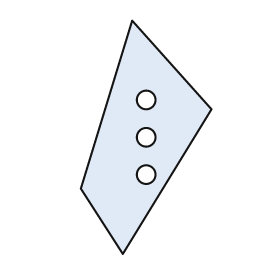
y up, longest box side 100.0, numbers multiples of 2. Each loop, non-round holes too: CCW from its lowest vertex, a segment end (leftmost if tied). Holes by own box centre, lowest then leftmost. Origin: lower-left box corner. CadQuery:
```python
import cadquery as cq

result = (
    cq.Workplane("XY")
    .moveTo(18.0, 0.0)
    .lineTo(56.0, 62.0)
    .lineTo(22.0, 100.0)
    .lineTo(0.0, 28.0)
    .close()
    .moveTo(28.0, 34.0)
    .circle(4.0)
    .moveTo(28.0, 50.0)
    .circle(4.0)
    .moveTo(28.0, 66.0)
    .circle(4.0)
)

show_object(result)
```